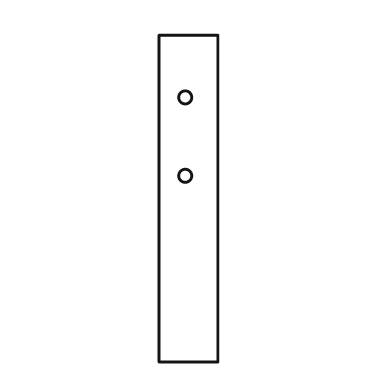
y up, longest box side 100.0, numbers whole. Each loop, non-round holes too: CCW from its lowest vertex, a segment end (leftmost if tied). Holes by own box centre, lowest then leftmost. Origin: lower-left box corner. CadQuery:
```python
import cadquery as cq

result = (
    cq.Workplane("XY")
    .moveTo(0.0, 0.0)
    .lineTo(18.0, 0.0)
    .lineTo(18.0, 100.0)
    .lineTo(0.0, 100.0)
    .close()
    .moveTo(8.0, 57.0)
    .circle(2.0)
    .moveTo(8.0, 81.0)
    .circle(2.0)
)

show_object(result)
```